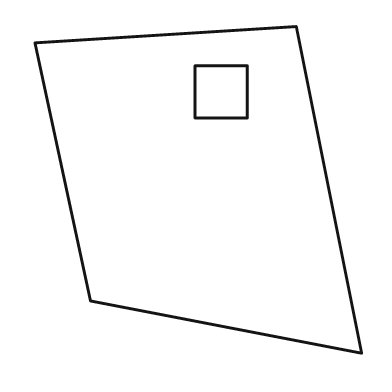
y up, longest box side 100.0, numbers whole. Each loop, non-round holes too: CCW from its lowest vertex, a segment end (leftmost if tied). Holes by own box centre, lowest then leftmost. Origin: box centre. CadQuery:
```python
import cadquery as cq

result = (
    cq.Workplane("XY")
    .moveTo(50.0, -50.0)
    .lineTo(30.0, 50.0)
    .lineTo(-50.0, 45.0)
    .lineTo(-33.0, -34.0)
    .close()
    .moveTo(-1.0, 22.0)
    .lineTo(15.0, 22.0)
    .lineTo(15.0, 38.0)
    .lineTo(-1.0, 38.0)
    .close()
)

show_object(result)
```